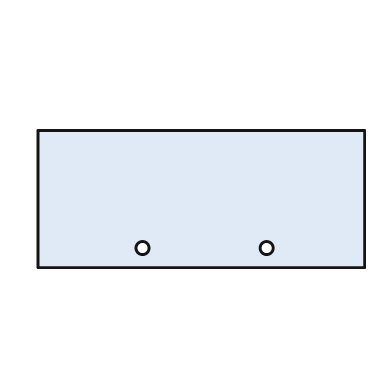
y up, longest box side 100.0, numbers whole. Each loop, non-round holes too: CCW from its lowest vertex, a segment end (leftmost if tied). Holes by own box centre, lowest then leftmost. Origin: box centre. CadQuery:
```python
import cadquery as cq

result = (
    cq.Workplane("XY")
    .moveTo(-50.0, -21.0)
    .lineTo(50.0, -21.0)
    .lineTo(50.0, 21.0)
    .lineTo(-50.0, 21.0)
    .close()
    .moveTo(-18.0, -15.0)
    .circle(2.0)
    .moveTo(20.0, -15.0)
    .circle(2.0)
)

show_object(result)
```